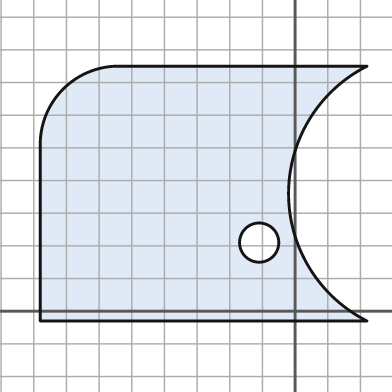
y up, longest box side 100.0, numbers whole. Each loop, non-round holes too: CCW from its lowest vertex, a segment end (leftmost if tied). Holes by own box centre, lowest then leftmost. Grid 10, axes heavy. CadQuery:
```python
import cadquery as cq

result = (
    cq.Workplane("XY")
    .moveTo(-78.0, -3.0)
    .lineTo(22.0, -3.0)
    .threePointArc((-2.0, 36.0), (22.0, 75.0))
    .lineTo(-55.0, 75.0)
    .threePointArc((-71.0, 68.0), (-78.0, 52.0))
    .close()
    .moveTo(-11.0, 21.0)
    .circle(6.0)
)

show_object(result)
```